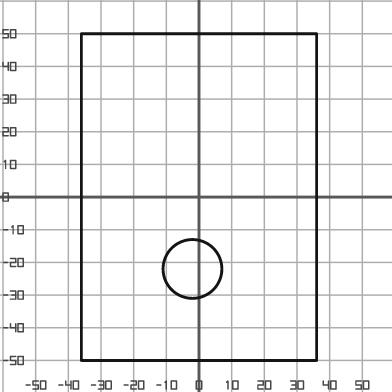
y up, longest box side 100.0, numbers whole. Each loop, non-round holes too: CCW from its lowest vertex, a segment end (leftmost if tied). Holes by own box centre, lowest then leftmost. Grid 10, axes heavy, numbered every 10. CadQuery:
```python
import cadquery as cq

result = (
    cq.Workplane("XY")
    .moveTo(-36.0, -50.0)
    .lineTo(36.0, -50.0)
    .lineTo(36.0, 50.0)
    .lineTo(-36.0, 50.0)
    .close()
    .moveTo(-2.0, -22.0)
    .circle(9.0)
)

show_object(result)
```